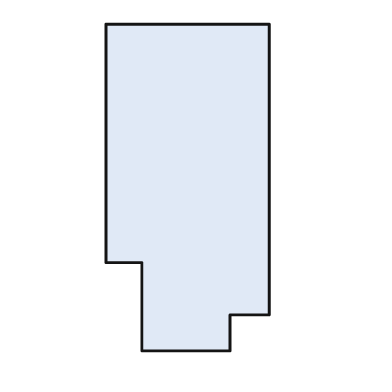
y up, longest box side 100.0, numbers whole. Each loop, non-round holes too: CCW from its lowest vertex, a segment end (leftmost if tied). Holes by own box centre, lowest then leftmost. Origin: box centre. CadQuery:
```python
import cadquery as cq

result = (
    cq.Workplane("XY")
    .moveTo(-14.0, -50.0)
    .lineTo(13.0, -50.0)
    .lineTo(13.0, -39.0)
    .lineTo(25.0, -39.0)
    .lineTo(25.0, 50.0)
    .lineTo(-25.0, 50.0)
    .lineTo(-25.0, -23.0)
    .lineTo(-14.0, -23.0)
    .close()
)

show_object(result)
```